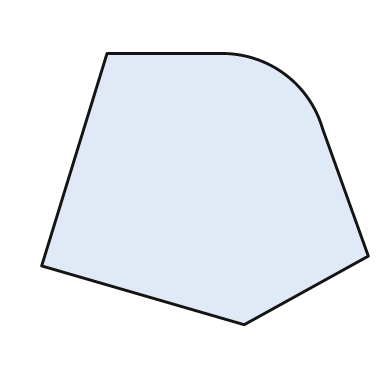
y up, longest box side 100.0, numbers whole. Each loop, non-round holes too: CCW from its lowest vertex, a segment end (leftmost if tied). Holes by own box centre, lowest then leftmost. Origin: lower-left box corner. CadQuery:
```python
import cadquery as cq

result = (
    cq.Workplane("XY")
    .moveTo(62.0, 0.0)
    .lineTo(100.0, 21.0)
    .lineTo(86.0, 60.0)
    .threePointArc((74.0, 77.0), (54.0, 83.0))
    .lineTo(20.0, 83.0)
    .lineTo(0.0, 18.0)
    .close()
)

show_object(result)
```